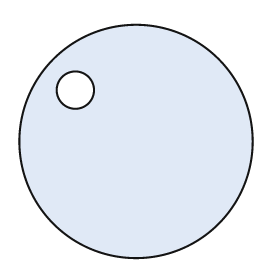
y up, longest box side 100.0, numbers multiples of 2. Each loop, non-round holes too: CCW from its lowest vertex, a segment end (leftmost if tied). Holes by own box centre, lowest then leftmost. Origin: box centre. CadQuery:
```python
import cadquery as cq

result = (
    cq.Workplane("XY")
    .moveTo(0.0, 0.0)
    .circle(50.0)
    .moveTo(-26.0, 22.0)
    .circle(8.0)
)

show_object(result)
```